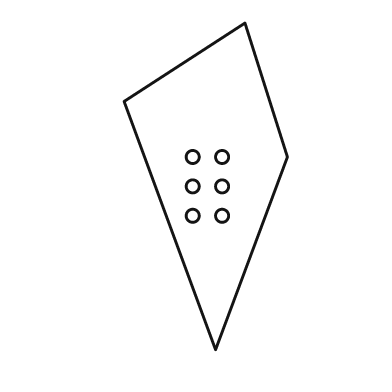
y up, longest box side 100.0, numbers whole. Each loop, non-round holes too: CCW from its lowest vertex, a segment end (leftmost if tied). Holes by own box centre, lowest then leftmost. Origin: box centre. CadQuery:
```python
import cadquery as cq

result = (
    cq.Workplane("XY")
    .moveTo(3.0, -50.0)
    .lineTo(25.0, 9.0)
    .lineTo(12.0, 50.0)
    .lineTo(-25.0, 26.0)
    .close()
    .moveTo(-4.0, -9.0)
    .circle(2.0)
    .moveTo(5.0, -9.0)
    .circle(2.0)
    .moveTo(-4.0, 0.0)
    .circle(2.0)
    .moveTo(5.0, 0.0)
    .circle(2.0)
    .moveTo(-4.0, 9.0)
    .circle(2.0)
    .moveTo(5.0, 9.0)
    .circle(2.0)
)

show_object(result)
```